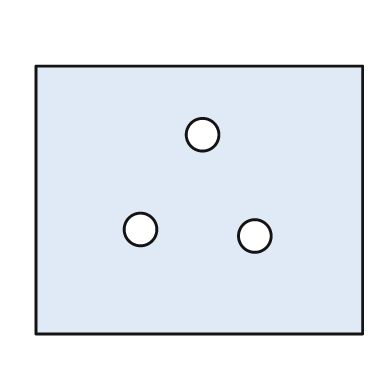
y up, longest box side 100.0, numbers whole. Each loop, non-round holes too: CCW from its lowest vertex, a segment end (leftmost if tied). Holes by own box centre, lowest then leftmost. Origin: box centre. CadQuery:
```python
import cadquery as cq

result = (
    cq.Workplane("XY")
    .moveTo(-50.0, -41.0)
    .lineTo(50.0, -41.0)
    .lineTo(50.0, 41.0)
    .lineTo(-50.0, 41.0)
    .close()
    .moveTo(17.0, -11.0)
    .circle(5.0)
    .moveTo(-18.0, -9.0)
    .circle(5.0)
    .moveTo(1.0, 20.0)
    .circle(5.0)
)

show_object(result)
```